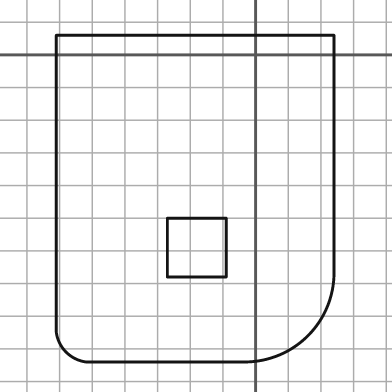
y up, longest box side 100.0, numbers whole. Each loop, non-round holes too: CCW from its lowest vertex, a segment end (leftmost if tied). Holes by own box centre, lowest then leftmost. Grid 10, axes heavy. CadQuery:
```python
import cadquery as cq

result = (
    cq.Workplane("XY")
    .moveTo(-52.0, -94.0)
    .lineTo(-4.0, -94.0)
    .threePointArc((16.0, -86.0), (24.0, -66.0))
    .lineTo(24.0, 6.0)
    .lineTo(-61.0, 6.0)
    .lineTo(-61.0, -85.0)
    .threePointArc((-58.0, -91.0), (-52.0, -94.0))
    .close()
    .moveTo(-27.0, -68.0)
    .lineTo(-9.0, -68.0)
    .lineTo(-9.0, -50.0)
    .lineTo(-27.0, -50.0)
    .close()
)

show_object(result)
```